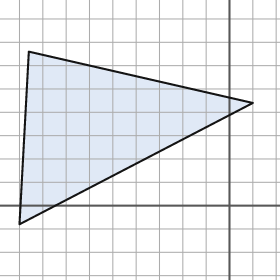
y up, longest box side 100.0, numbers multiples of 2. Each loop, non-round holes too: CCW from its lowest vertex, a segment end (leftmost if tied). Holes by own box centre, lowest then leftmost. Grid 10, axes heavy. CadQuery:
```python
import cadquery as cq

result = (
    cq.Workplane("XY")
    .moveTo(-90.0, -8.0)
    .lineTo(10.0, 44.0)
    .lineTo(-86.0, 66.0)
    .close()
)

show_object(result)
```